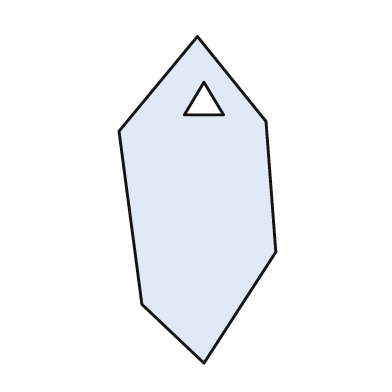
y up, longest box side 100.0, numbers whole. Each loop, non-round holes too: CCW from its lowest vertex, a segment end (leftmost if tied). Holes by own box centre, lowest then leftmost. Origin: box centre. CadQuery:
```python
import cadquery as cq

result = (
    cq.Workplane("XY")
    .moveTo(2.0, -50.0)
    .lineTo(24.0, -16.0)
    .lineTo(21.0, 24.0)
    .lineTo(0.0, 50.0)
    .lineTo(-24.0, 21.0)
    .lineTo(-17.0, -32.0)
    .close()
    .moveTo(-4.0, 26.0)
    .lineTo(8.0, 26.0)
    .lineTo(2.0, 36.0)
    .close()
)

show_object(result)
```